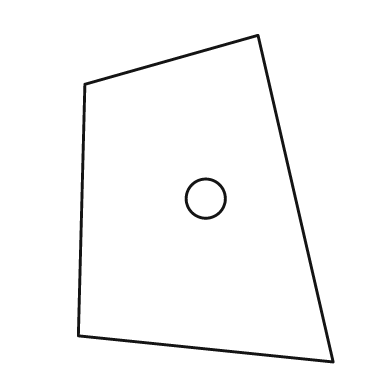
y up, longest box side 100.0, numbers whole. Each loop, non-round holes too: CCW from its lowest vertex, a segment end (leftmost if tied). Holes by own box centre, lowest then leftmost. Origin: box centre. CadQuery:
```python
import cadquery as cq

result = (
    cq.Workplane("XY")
    .moveTo(39.0, -50.0)
    .lineTo(16.0, 50.0)
    .lineTo(-37.0, 35.0)
    .lineTo(-39.0, -42.0)
    .close()
    .moveTo(0.0, 0.0)
    .circle(6.0)
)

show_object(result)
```